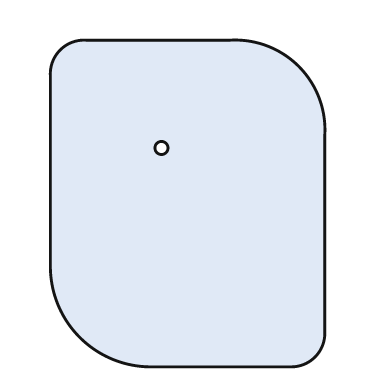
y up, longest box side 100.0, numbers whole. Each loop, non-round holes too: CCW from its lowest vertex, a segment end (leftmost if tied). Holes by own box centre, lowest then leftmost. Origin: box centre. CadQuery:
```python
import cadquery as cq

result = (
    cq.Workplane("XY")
    .moveTo(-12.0, -50.0)
    .lineTo(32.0, -50.0)
    .threePointArc((39.0, -47.0), (42.0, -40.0))
    .lineTo(42.0, 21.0)
    .threePointArc((34.0, 42.0), (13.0, 50.0))
    .lineTo(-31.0, 50.0)
    .threePointArc((-39.0, 47.0), (-42.0, 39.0))
    .lineTo(-42.0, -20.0)
    .threePointArc((-33.0, -41.0), (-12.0, -50.0))
    .close()
    .moveTo(-8.0, 17.0)
    .circle(2.0)
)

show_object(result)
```